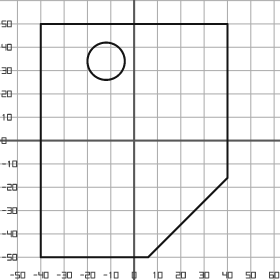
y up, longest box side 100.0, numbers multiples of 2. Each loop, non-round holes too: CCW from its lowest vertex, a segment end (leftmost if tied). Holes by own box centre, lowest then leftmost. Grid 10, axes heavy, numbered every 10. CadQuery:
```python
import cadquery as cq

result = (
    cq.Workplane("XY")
    .moveTo(-40.0, -50.0)
    .lineTo(6.0, -50.0)
    .lineTo(40.0, -16.0)
    .lineTo(40.0, 50.0)
    .lineTo(-40.0, 50.0)
    .close()
    .moveTo(-12.0, 34.0)
    .circle(8.0)
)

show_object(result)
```